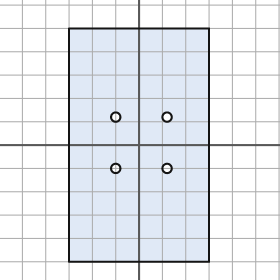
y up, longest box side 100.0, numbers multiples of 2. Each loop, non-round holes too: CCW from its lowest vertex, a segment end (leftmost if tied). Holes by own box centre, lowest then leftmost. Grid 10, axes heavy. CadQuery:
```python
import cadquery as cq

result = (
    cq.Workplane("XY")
    .moveTo(-30.0, -50.0)
    .lineTo(30.0, -50.0)
    .lineTo(30.0, 50.0)
    .lineTo(-30.0, 50.0)
    .close()
    .moveTo(-10.0, -10.0)
    .circle(2.0)
    .moveTo(12.0, -10.0)
    .circle(2.0)
    .moveTo(-10.0, 12.0)
    .circle(2.0)
    .moveTo(12.0, 12.0)
    .circle(2.0)
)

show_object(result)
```